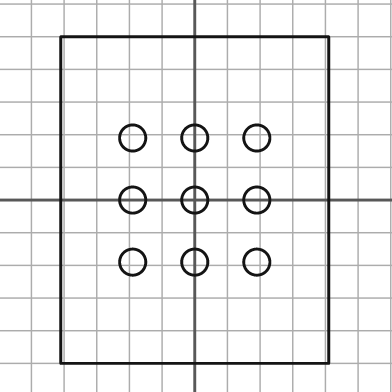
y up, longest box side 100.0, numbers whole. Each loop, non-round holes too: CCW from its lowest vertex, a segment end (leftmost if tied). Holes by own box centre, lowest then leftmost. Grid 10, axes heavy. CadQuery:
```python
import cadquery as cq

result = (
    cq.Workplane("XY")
    .moveTo(-41.0, -50.0)
    .lineTo(41.0, -50.0)
    .lineTo(41.0, 50.0)
    .lineTo(-41.0, 50.0)
    .close()
    .moveTo(-19.0, -19.0)
    .circle(4.0)
    .moveTo(0.0, -19.0)
    .circle(4.0)
    .moveTo(19.0, -19.0)
    .circle(4.0)
    .moveTo(-19.0, 0.0)
    .circle(4.0)
    .moveTo(0.0, 0.0)
    .circle(4.0)
    .moveTo(19.0, 0.0)
    .circle(4.0)
    .moveTo(-19.0, 19.0)
    .circle(4.0)
    .moveTo(0.0, 19.0)
    .circle(4.0)
    .moveTo(19.0, 19.0)
    .circle(4.0)
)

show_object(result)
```